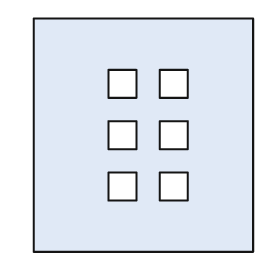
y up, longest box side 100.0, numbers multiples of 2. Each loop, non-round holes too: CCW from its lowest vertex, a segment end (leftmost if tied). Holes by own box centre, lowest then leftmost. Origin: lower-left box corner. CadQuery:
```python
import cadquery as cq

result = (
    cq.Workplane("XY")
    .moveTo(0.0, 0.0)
    .lineTo(94.0, 0.0)
    .lineTo(94.0, 100.0)
    .lineTo(0.0, 100.0)
    .close()
    .moveTo(32.0, 22.0)
    .lineTo(44.0, 22.0)
    .lineTo(44.0, 34.0)
    .lineTo(32.0, 34.0)
    .close()
    .moveTo(54.0, 22.0)
    .lineTo(66.0, 22.0)
    .lineTo(66.0, 34.0)
    .lineTo(54.0, 34.0)
    .close()
    .moveTo(32.0, 44.0)
    .lineTo(44.0, 44.0)
    .lineTo(44.0, 56.0)
    .lineTo(32.0, 56.0)
    .close()
    .moveTo(54.0, 44.0)
    .lineTo(66.0, 44.0)
    .lineTo(66.0, 56.0)
    .lineTo(54.0, 56.0)
    .close()
    .moveTo(32.0, 66.0)
    .lineTo(44.0, 66.0)
    .lineTo(44.0, 78.0)
    .lineTo(32.0, 78.0)
    .close()
    .moveTo(54.0, 66.0)
    .lineTo(66.0, 66.0)
    .lineTo(66.0, 78.0)
    .lineTo(54.0, 78.0)
    .close()
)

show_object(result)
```